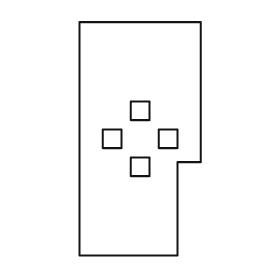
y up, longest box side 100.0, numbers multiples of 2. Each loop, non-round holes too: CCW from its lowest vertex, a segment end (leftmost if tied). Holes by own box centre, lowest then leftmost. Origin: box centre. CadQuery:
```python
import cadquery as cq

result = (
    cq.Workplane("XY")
    .moveTo(-26.0, -50.0)
    .lineTo(16.0, -50.0)
    .lineTo(16.0, -10.0)
    .lineTo(26.0, -10.0)
    .lineTo(26.0, 50.0)
    .lineTo(-26.0, 50.0)
    .close()
    .moveTo(-4.0, -16.0)
    .lineTo(4.0, -16.0)
    .lineTo(4.0, -8.0)
    .lineTo(-4.0, -8.0)
    .close()
    .moveTo(-16.0, -4.0)
    .lineTo(-8.0, -4.0)
    .lineTo(-8.0, 4.0)
    .lineTo(-16.0, 4.0)
    .close()
    .moveTo(8.0, -4.0)
    .lineTo(16.0, -4.0)
    .lineTo(16.0, 4.0)
    .lineTo(8.0, 4.0)
    .close()
    .moveTo(-4.0, 8.0)
    .lineTo(4.0, 8.0)
    .lineTo(4.0, 16.0)
    .lineTo(-4.0, 16.0)
    .close()
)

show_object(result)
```